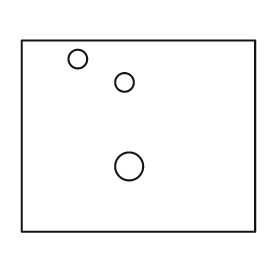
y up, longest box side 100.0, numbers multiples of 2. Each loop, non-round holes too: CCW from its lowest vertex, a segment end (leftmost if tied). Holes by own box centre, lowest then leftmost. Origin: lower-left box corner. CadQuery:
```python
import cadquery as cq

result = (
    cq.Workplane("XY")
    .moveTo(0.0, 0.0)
    .lineTo(100.0, 0.0)
    .lineTo(100.0, 82.0)
    .lineTo(0.0, 82.0)
    .close()
    .moveTo(46.0, 28.0)
    .circle(6.0)
    .moveTo(44.0, 64.0)
    .circle(4.0)
    .moveTo(24.0, 74.0)
    .circle(4.0)
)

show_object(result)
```